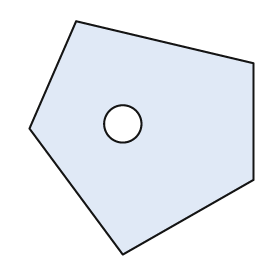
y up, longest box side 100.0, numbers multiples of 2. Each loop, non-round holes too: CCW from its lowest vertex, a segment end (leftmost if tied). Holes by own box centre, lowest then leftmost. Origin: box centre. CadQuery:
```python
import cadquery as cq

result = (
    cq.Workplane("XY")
    .moveTo(-8.0, -50.0)
    .lineTo(48.0, -18.0)
    .lineTo(48.0, 32.0)
    .lineTo(-28.0, 50.0)
    .lineTo(-48.0, 4.0)
    .close()
    .moveTo(-8.0, 6.0)
    .circle(8.0)
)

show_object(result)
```